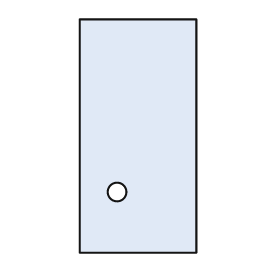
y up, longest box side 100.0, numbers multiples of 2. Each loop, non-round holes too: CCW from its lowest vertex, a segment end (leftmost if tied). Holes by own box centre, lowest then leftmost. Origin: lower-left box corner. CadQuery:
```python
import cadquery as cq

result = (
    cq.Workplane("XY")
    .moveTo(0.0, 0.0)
    .lineTo(50.0, 0.0)
    .lineTo(50.0, 100.0)
    .lineTo(0.0, 100.0)
    .close()
    .moveTo(16.0, 26.0)
    .circle(4.0)
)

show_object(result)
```